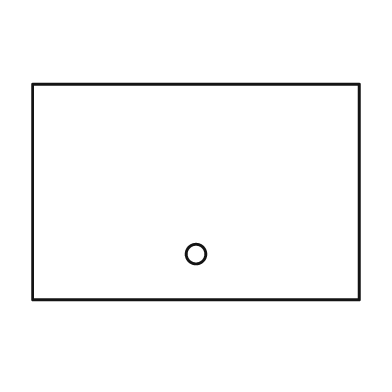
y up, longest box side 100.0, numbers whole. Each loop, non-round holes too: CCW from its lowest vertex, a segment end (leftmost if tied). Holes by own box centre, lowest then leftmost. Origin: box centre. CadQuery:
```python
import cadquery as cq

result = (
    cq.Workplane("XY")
    .moveTo(-50.0, -33.0)
    .lineTo(50.0, -33.0)
    .lineTo(50.0, 33.0)
    .lineTo(-50.0, 33.0)
    .close()
    .moveTo(0.0, -19.0)
    .circle(3.0)
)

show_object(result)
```